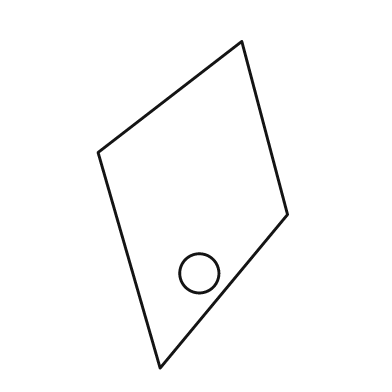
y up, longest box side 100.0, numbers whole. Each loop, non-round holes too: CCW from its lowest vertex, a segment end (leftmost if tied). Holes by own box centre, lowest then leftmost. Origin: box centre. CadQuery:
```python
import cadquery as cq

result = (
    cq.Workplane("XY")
    .moveTo(-10.0, -50.0)
    .lineTo(29.0, -3.0)
    .lineTo(15.0, 50.0)
    .lineTo(-29.0, 16.0)
    .close()
    .moveTo(2.0, -21.0)
    .circle(6.0)
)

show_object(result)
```